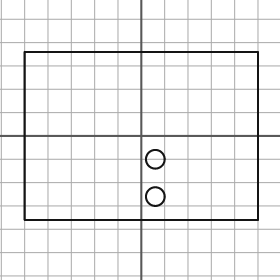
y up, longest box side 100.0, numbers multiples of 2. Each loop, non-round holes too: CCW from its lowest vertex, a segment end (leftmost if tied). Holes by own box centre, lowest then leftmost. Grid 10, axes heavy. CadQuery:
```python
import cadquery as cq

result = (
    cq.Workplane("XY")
    .moveTo(-50.0, -36.0)
    .lineTo(50.0, -36.0)
    .lineTo(50.0, 36.0)
    .lineTo(-50.0, 36.0)
    .close()
    .moveTo(6.0, -26.0)
    .circle(4.0)
    .moveTo(6.0, -10.0)
    .circle(4.0)
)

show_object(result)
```